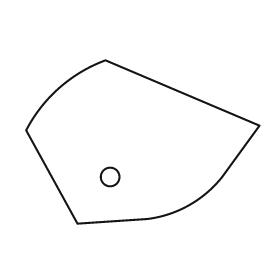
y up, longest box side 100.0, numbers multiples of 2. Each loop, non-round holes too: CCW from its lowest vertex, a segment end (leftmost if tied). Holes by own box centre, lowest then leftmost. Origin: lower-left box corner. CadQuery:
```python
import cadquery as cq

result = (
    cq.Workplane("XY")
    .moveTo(22.0, 0.0)
    .lineTo(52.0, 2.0)
    .threePointArc((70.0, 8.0), (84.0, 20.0))
    .lineTo(100.0, 42.0)
    .lineTo(34.0, 70.0)
    .threePointArc((14.0, 58.0), (0.0, 40.0))
    .close()
    .moveTo(36.0, 20.0)
    .circle(4.0)
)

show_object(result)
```